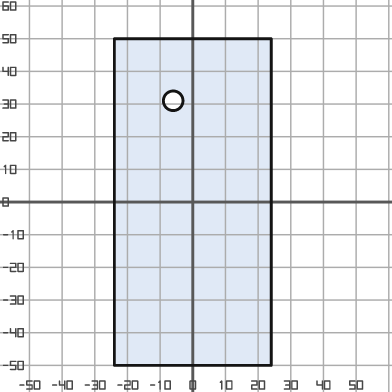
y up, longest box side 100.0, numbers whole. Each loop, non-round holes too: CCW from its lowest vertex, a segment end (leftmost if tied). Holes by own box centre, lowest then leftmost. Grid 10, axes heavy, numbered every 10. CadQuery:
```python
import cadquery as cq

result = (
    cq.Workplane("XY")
    .moveTo(-24.0, -50.0)
    .lineTo(24.0, -50.0)
    .lineTo(24.0, 50.0)
    .lineTo(-24.0, 50.0)
    .close()
    .moveTo(-6.0, 31.0)
    .circle(3.0)
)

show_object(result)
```